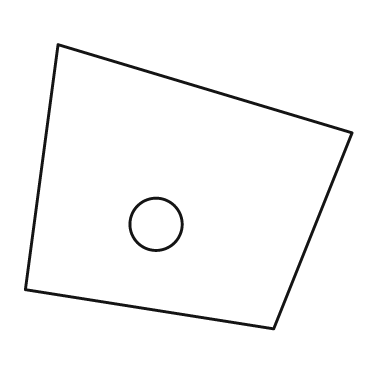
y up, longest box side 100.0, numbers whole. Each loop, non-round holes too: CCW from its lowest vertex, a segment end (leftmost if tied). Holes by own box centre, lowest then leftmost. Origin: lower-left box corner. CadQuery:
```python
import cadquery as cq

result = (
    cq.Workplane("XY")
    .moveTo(76.0, 0.0)
    .lineTo(100.0, 60.0)
    .lineTo(10.0, 87.0)
    .lineTo(0.0, 12.0)
    .close()
    .moveTo(40.0, 32.0)
    .circle(8.0)
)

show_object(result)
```